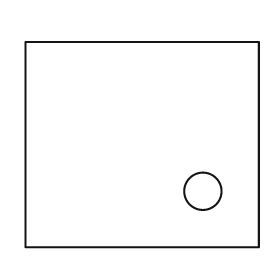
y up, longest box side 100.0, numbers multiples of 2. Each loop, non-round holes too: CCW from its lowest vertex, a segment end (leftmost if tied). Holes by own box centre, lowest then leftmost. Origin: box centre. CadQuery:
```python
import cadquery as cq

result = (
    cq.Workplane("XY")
    .moveTo(-50.0, -44.0)
    .lineTo(50.0, -44.0)
    .lineTo(50.0, 44.0)
    .lineTo(-50.0, 44.0)
    .close()
    .moveTo(26.0, -20.0)
    .circle(8.0)
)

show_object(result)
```